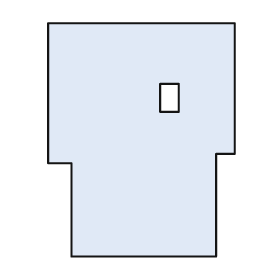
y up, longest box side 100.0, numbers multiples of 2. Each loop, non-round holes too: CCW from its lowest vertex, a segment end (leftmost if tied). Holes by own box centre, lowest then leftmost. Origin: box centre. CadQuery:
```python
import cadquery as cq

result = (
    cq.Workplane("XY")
    .moveTo(-30.0, -50.0)
    .lineTo(32.0, -50.0)
    .lineTo(32.0, -6.0)
    .lineTo(40.0, -6.0)
    .lineTo(40.0, 50.0)
    .lineTo(-40.0, 50.0)
    .lineTo(-40.0, -10.0)
    .lineTo(-30.0, -10.0)
    .close()
    .moveTo(8.0, 12.0)
    .lineTo(16.0, 12.0)
    .lineTo(16.0, 24.0)
    .lineTo(8.0, 24.0)
    .close()
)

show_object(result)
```